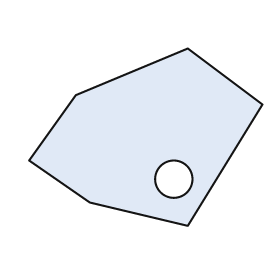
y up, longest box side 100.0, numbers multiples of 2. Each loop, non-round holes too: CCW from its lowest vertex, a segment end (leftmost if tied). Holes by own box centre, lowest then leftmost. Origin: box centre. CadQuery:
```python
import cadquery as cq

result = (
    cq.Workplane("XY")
    .moveTo(18.0, -38.0)
    .lineTo(50.0, 14.0)
    .lineTo(18.0, 38.0)
    .lineTo(-30.0, 18.0)
    .lineTo(-50.0, -10.0)
    .lineTo(-24.0, -28.0)
    .close()
    .moveTo(12.0, -18.0)
    .circle(8.0)
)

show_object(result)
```